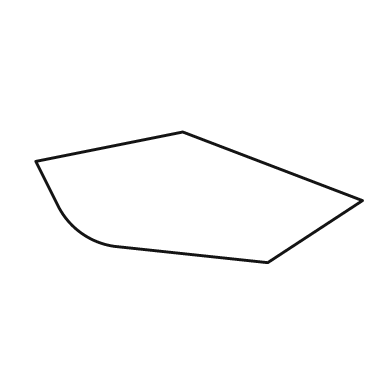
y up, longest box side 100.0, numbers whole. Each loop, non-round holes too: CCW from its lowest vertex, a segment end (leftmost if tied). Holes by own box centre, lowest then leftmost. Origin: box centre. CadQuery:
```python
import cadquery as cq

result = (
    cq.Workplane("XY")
    .moveTo(21.0, -20.0)
    .lineTo(50.0, -1.0)
    .lineTo(-5.0, 20.0)
    .lineTo(-50.0, 11.0)
    .lineTo(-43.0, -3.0)
    .threePointArc((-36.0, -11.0), (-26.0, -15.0))
    .close()
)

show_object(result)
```